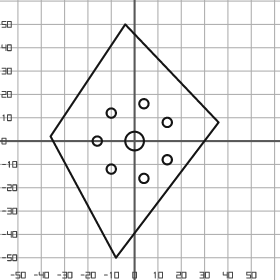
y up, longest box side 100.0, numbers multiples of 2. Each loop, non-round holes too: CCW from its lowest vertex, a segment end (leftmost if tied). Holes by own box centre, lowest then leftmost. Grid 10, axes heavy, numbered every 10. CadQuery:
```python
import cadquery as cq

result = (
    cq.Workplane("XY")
    .moveTo(-8.0, -50.0)
    .lineTo(36.0, 8.0)
    .lineTo(-4.0, 50.0)
    .lineTo(-36.0, 2.0)
    .close()
    .moveTo(4.0, -16.0)
    .circle(2.0)
    .moveTo(-10.0, -12.0)
    .circle(2.0)
    .moveTo(14.0, -8.0)
    .circle(2.0)
    .moveTo(-16.0, 0.0)
    .circle(2.0)
    .moveTo(0.0, 0.0)
    .circle(4.0)
    .moveTo(14.0, 8.0)
    .circle(2.0)
    .moveTo(-10.0, 12.0)
    .circle(2.0)
    .moveTo(4.0, 16.0)
    .circle(2.0)
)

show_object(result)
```